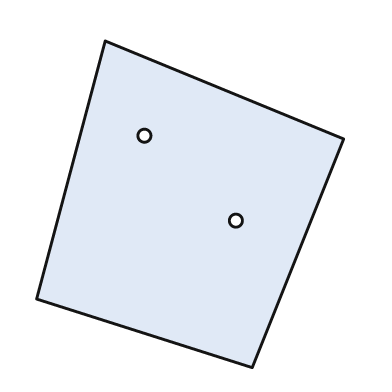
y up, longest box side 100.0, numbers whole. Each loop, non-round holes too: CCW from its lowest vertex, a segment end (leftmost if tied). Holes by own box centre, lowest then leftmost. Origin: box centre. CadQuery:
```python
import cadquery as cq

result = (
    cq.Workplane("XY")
    .moveTo(19.0, -50.0)
    .lineTo(47.0, 20.0)
    .lineTo(-26.0, 50.0)
    .lineTo(-47.0, -29.0)
    .close()
    .moveTo(14.0, -5.0)
    .circle(2.0)
    .moveTo(-14.0, 21.0)
    .circle(2.0)
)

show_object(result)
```